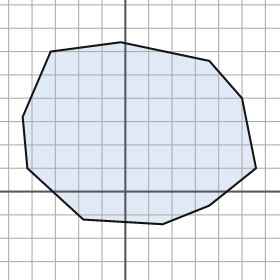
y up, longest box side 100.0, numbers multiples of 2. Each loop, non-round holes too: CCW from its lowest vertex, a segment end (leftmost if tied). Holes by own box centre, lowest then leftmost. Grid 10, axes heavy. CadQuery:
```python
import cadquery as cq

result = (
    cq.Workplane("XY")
    .moveTo(16.0, -14.0)
    .lineTo(36.0, -6.0)
    .lineTo(56.0, 10.0)
    .lineTo(50.0, 40.0)
    .lineTo(36.0, 56.0)
    .lineTo(-2.0, 64.0)
    .lineTo(-32.0, 60.0)
    .lineTo(-44.0, 32.0)
    .lineTo(-42.0, 10.0)
    .lineTo(-18.0, -12.0)
    .close()
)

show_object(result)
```